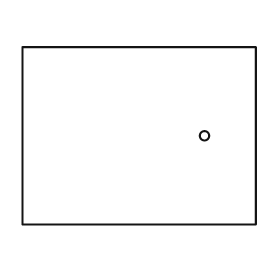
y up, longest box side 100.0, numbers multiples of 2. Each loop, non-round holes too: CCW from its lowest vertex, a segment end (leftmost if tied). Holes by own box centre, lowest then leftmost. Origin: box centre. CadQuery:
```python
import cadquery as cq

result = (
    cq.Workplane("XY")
    .moveTo(-50.0, -38.0)
    .lineTo(50.0, -38.0)
    .lineTo(50.0, 38.0)
    .lineTo(-50.0, 38.0)
    .close()
    .moveTo(28.0, 0.0)
    .circle(2.0)
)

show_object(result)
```